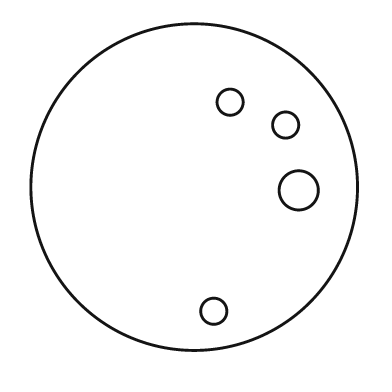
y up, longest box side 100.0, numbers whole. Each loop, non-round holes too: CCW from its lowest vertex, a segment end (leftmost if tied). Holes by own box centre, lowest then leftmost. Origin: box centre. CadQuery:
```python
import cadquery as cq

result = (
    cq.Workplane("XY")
    .moveTo(0.0, 0.0)
    .circle(50.0)
    .moveTo(6.0, -38.0)
    .circle(4.0)
    .moveTo(32.0, -1.0)
    .circle(6.0)
    .moveTo(28.0, 19.0)
    .circle(4.0)
    .moveTo(11.0, 26.0)
    .circle(4.0)
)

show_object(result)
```